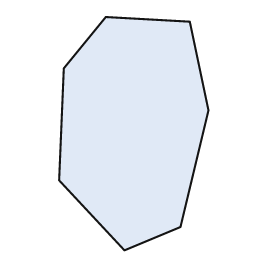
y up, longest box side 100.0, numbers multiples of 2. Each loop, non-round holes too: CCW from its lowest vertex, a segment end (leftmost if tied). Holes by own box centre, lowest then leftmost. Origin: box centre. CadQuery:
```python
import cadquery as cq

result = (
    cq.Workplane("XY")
    .moveTo(-4.0, -50.0)
    .lineTo(20.0, -40.0)
    .lineTo(32.0, 10.0)
    .lineTo(24.0, 48.0)
    .lineTo(-12.0, 50.0)
    .lineTo(-30.0, 28.0)
    .lineTo(-32.0, -20.0)
    .close()
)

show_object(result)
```